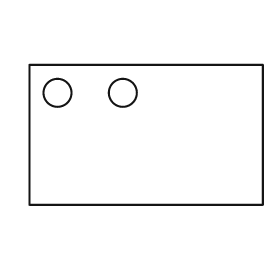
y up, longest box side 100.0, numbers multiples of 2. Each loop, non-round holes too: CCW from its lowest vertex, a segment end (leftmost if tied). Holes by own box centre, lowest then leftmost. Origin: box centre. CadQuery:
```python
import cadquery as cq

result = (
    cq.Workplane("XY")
    .moveTo(-50.0, -30.0)
    .lineTo(50.0, -30.0)
    .lineTo(50.0, 30.0)
    .lineTo(-50.0, 30.0)
    .close()
    .moveTo(-38.0, 18.0)
    .circle(6.0)
    .moveTo(-10.0, 18.0)
    .circle(6.0)
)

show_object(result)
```